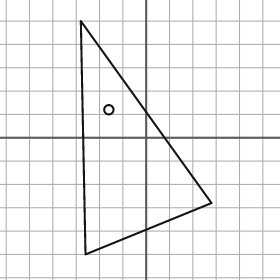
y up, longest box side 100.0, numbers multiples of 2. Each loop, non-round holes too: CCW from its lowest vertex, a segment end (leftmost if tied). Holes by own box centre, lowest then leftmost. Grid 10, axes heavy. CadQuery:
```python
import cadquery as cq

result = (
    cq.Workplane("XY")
    .moveTo(-26.0, -50.0)
    .lineTo(28.0, -28.0)
    .lineTo(-28.0, 50.0)
    .close()
    .moveTo(-16.0, 12.0)
    .circle(2.0)
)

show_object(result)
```